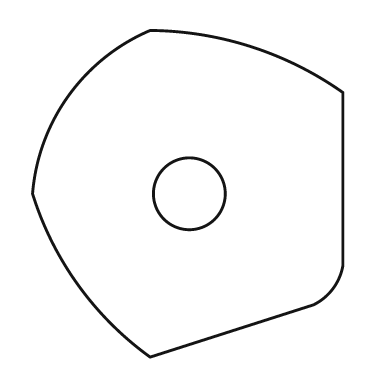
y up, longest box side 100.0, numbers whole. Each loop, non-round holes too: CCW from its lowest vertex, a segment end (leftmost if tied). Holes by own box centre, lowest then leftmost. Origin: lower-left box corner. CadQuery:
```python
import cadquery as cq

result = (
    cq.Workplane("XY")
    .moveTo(36.0, 0.0)
    .lineTo(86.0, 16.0)
    .threePointArc((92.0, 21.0), (95.0, 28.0))
    .lineTo(95.0, 81.0)
    .threePointArc((67.0, 95.0), (36.0, 100.0))
    .threePointArc((11.0, 80.0), (0.0, 50.0))
    .threePointArc((14.0, 22.0), (36.0, 0.0))
    .close()
    .moveTo(48.0, 50.0)
    .circle(11.0)
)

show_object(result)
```